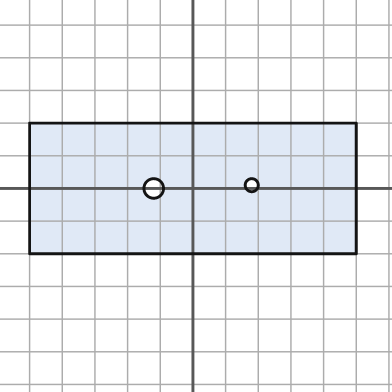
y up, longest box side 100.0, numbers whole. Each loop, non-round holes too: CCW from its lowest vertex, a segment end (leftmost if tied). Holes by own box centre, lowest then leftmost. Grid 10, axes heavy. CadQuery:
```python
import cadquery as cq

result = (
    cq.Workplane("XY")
    .moveTo(-50.0, -20.0)
    .lineTo(50.0, -20.0)
    .lineTo(50.0, 20.0)
    .lineTo(-50.0, 20.0)
    .close()
    .moveTo(-12.0, 0.0)
    .circle(3.0)
    .moveTo(18.0, 1.0)
    .circle(2.0)
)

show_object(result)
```